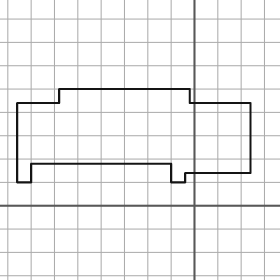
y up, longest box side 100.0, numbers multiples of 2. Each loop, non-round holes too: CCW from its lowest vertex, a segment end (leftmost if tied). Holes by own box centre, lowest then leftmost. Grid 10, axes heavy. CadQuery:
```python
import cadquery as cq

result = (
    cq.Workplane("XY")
    .moveTo(-76.0, 10.0)
    .lineTo(-70.0, 10.0)
    .lineTo(-70.0, 18.0)
    .lineTo(-10.0, 18.0)
    .lineTo(-10.0, 10.0)
    .lineTo(-4.0, 10.0)
    .lineTo(-4.0, 14.0)
    .lineTo(24.0, 14.0)
    .lineTo(24.0, 44.0)
    .lineTo(-2.0, 44.0)
    .lineTo(-2.0, 50.0)
    .lineTo(-58.0, 50.0)
    .lineTo(-58.0, 44.0)
    .lineTo(-76.0, 44.0)
    .close()
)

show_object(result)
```